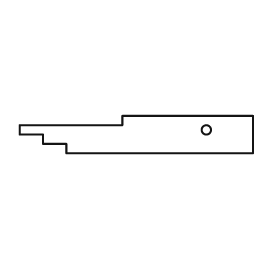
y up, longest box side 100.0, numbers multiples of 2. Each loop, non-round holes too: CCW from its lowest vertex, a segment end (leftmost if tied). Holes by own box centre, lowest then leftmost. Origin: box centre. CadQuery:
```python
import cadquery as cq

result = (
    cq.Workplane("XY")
    .moveTo(-30.0, -8.0)
    .lineTo(50.0, -8.0)
    .lineTo(50.0, 8.0)
    .lineTo(-6.0, 8.0)
    .lineTo(-6.0, 4.0)
    .lineTo(-50.0, 4.0)
    .lineTo(-50.0, 0.0)
    .lineTo(-40.0, 0.0)
    .lineTo(-40.0, -4.0)
    .lineTo(-30.0, -4.0)
    .close()
    .moveTo(30.0, 2.0)
    .circle(2.0)
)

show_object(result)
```